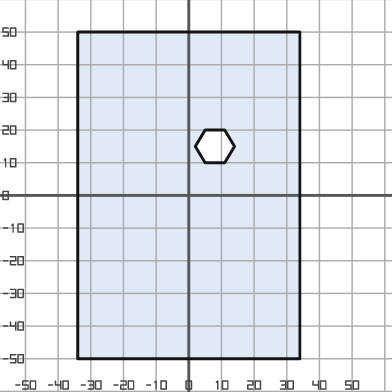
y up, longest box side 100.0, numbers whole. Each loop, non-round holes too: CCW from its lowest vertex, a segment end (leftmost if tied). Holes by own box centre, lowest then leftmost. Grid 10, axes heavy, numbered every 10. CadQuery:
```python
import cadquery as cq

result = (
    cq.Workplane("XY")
    .moveTo(-34.0, -50.0)
    .lineTo(34.0, -50.0)
    .lineTo(34.0, 50.0)
    .lineTo(-34.0, 50.0)
    .close()
    .moveTo(5.0, 10.0)
    .lineTo(11.0, 10.0)
    .lineTo(14.0, 15.0)
    .lineTo(11.0, 20.0)
    .lineTo(5.0, 20.0)
    .lineTo(2.0, 15.0)
    .close()
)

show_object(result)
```